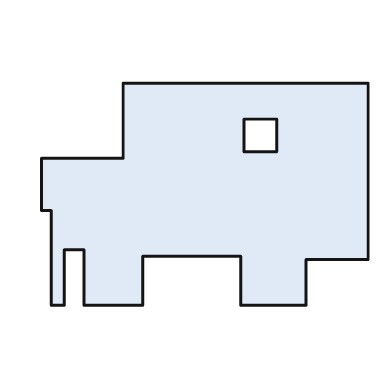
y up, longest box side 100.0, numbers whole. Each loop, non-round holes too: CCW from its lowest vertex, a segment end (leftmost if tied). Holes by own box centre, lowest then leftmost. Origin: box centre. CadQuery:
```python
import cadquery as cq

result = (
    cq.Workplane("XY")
    .moveTo(-47.0, -34.0)
    .lineTo(-43.0, -34.0)
    .lineTo(-43.0, -17.0)
    .lineTo(-37.0, -17.0)
    .lineTo(-37.0, -34.0)
    .lineTo(-19.0, -34.0)
    .lineTo(-19.0, -19.0)
    .lineTo(11.0, -19.0)
    .lineTo(11.0, -34.0)
    .lineTo(31.0, -34.0)
    .lineTo(31.0, -20.0)
    .lineTo(50.0, -20.0)
    .lineTo(50.0, 34.0)
    .lineTo(-25.0, 34.0)
    .lineTo(-25.0, 11.0)
    .lineTo(-50.0, 11.0)
    .lineTo(-50.0, -5.0)
    .lineTo(-47.0, -5.0)
    .close()
    .moveTo(12.0, 13.0)
    .lineTo(22.0, 13.0)
    .lineTo(22.0, 23.0)
    .lineTo(12.0, 23.0)
    .close()
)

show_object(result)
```